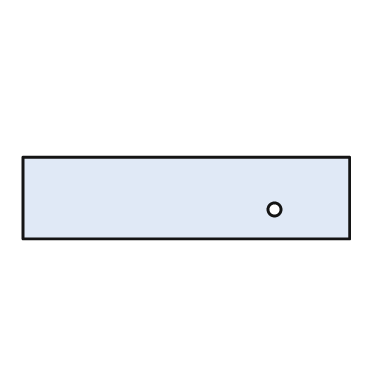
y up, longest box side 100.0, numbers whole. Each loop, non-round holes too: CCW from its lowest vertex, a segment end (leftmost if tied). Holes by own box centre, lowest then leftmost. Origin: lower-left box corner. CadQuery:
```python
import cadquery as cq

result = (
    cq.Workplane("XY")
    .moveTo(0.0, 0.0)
    .lineTo(100.0, 0.0)
    .lineTo(100.0, 25.0)
    .lineTo(0.0, 25.0)
    .close()
    .moveTo(77.0, 9.0)
    .circle(2.0)
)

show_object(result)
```